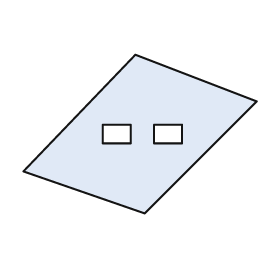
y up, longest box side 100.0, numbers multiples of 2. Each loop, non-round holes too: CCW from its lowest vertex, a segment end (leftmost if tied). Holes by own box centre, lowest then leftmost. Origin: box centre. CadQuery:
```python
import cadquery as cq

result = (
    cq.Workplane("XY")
    .moveTo(2.0, -34.0)
    .lineTo(50.0, 14.0)
    .lineTo(-2.0, 34.0)
    .lineTo(-50.0, -16.0)
    .close()
    .moveTo(-16.0, -4.0)
    .lineTo(-4.0, -4.0)
    .lineTo(-4.0, 4.0)
    .lineTo(-16.0, 4.0)
    .close()
    .moveTo(6.0, -4.0)
    .lineTo(18.0, -4.0)
    .lineTo(18.0, 4.0)
    .lineTo(6.0, 4.0)
    .close()
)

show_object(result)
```